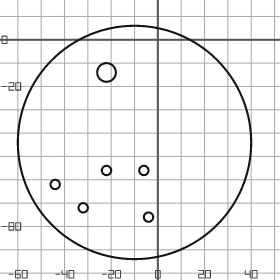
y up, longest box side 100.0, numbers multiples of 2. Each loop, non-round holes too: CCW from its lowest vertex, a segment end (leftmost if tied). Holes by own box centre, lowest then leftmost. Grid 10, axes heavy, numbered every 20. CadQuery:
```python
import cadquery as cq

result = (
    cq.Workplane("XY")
    .moveTo(-10.0, -44.0)
    .circle(50.0)
    .moveTo(-4.0, -76.0)
    .circle(2.0)
    .moveTo(-32.0, -72.0)
    .circle(2.0)
    .moveTo(-44.0, -62.0)
    .circle(2.0)
    .moveTo(-22.0, -56.0)
    .circle(2.0)
    .moveTo(-6.0, -56.0)
    .circle(2.0)
    .moveTo(-22.0, -14.0)
    .circle(4.0)
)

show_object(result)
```